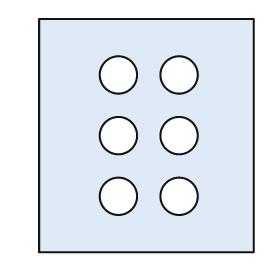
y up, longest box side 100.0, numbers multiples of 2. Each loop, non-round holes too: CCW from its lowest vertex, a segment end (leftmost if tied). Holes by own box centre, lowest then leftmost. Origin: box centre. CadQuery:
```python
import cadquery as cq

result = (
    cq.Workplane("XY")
    .moveTo(-46.0, -50.0)
    .lineTo(46.0, -50.0)
    .lineTo(46.0, 50.0)
    .lineTo(-46.0, 50.0)
    .close()
    .moveTo(-12.0, -26.0)
    .circle(8.0)
    .moveTo(14.0, -26.0)
    .circle(8.0)
    .moveTo(-12.0, 0.0)
    .circle(8.0)
    .moveTo(14.0, 0.0)
    .circle(8.0)
    .moveTo(-12.0, 26.0)
    .circle(8.0)
    .moveTo(14.0, 26.0)
    .circle(8.0)
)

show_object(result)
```